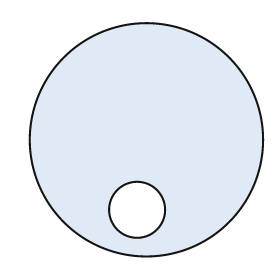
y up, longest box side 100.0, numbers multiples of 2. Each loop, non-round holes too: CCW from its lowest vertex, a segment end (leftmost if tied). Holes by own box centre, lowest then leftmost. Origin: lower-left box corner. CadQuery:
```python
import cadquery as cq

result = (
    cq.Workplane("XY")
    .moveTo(50.0, 50.0)
    .circle(50.0)
    .moveTo(46.0, 20.0)
    .circle(12.0)
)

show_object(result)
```